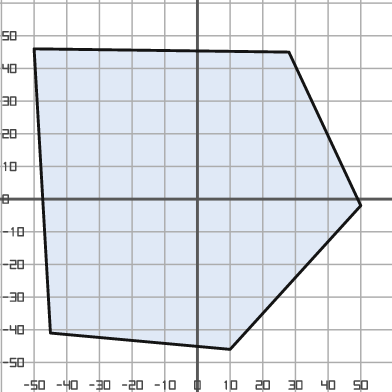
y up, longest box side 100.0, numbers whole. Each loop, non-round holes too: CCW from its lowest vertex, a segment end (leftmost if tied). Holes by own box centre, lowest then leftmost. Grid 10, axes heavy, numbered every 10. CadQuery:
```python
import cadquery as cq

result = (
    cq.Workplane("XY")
    .moveTo(10.0, -46.0)
    .lineTo(50.0, -2.0)
    .lineTo(28.0, 45.0)
    .lineTo(-50.0, 46.0)
    .lineTo(-45.0, -41.0)
    .close()
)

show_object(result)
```